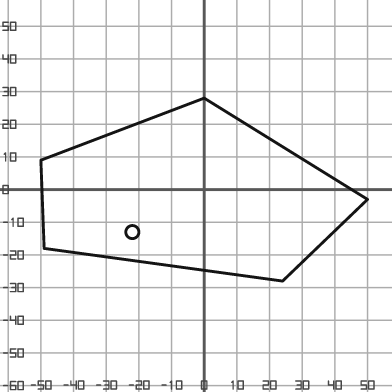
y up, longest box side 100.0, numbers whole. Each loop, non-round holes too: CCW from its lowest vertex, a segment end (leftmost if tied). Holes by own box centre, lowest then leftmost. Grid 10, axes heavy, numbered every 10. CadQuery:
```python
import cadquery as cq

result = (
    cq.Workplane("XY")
    .moveTo(24.0, -28.0)
    .lineTo(50.0, -3.0)
    .lineTo(0.0, 28.0)
    .lineTo(-50.0, 9.0)
    .lineTo(-49.0, -18.0)
    .close()
    .moveTo(-22.0, -13.0)
    .circle(2.0)
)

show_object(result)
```